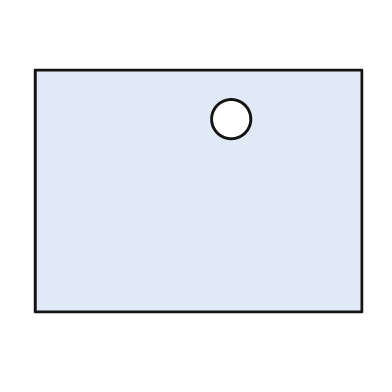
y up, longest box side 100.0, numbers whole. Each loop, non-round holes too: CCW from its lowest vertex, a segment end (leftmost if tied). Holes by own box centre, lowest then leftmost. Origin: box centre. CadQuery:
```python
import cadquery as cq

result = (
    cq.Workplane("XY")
    .moveTo(-50.0, -37.0)
    .lineTo(50.0, -37.0)
    .lineTo(50.0, 37.0)
    .lineTo(-50.0, 37.0)
    .close()
    .moveTo(10.0, 22.0)
    .circle(6.0)
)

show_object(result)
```